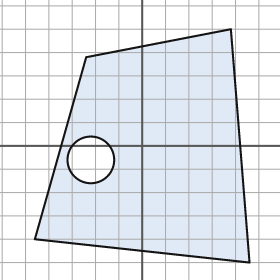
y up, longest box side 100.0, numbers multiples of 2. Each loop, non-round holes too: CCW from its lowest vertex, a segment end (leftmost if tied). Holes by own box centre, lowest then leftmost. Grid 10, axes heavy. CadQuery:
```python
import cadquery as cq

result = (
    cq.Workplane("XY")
    .moveTo(46.0, -50.0)
    .lineTo(38.0, 50.0)
    .lineTo(-24.0, 38.0)
    .lineTo(-46.0, -40.0)
    .close()
    .moveTo(-22.0, -6.0)
    .circle(10.0)
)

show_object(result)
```